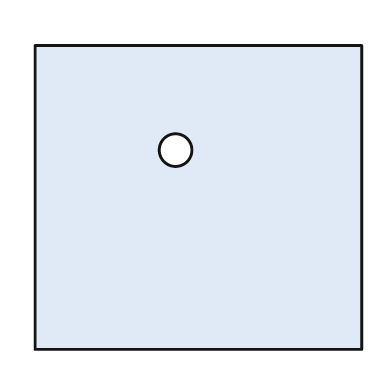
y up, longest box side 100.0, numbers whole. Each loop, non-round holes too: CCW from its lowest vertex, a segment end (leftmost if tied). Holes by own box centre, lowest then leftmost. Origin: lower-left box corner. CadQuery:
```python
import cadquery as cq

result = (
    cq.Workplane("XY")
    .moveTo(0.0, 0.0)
    .lineTo(100.0, 0.0)
    .lineTo(100.0, 93.0)
    .lineTo(0.0, 93.0)
    .close()
    .moveTo(43.0, 61.0)
    .circle(5.0)
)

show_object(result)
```